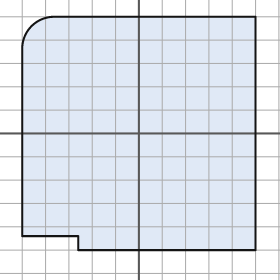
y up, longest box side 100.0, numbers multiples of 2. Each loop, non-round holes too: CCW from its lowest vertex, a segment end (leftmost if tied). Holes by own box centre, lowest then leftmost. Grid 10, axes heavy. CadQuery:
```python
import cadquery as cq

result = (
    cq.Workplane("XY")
    .moveTo(-26.0, -50.0)
    .lineTo(50.0, -50.0)
    .lineTo(50.0, 50.0)
    .lineTo(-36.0, 50.0)
    .threePointArc((-46.0, 46.0), (-50.0, 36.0))
    .lineTo(-50.0, -44.0)
    .lineTo(-26.0, -44.0)
    .close()
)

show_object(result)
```